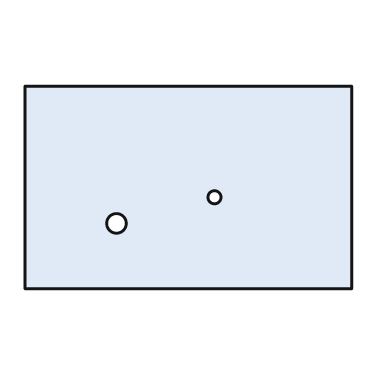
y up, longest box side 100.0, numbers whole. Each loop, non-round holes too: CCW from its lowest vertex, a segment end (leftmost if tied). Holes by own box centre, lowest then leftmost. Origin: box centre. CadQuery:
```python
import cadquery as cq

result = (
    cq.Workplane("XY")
    .moveTo(-50.0, -31.0)
    .lineTo(50.0, -31.0)
    .lineTo(50.0, 31.0)
    .lineTo(-50.0, 31.0)
    .close()
    .moveTo(-22.0, -11.0)
    .circle(3.0)
    .moveTo(8.0, -3.0)
    .circle(2.0)
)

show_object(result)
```